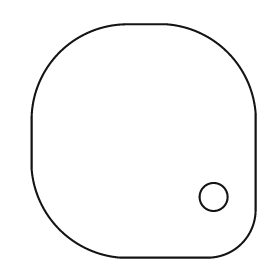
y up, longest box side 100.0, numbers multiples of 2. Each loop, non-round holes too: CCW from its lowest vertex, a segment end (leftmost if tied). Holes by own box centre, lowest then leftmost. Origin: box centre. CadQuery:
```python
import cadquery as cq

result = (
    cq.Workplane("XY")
    .moveTo(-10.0, -50.0)
    .lineTo(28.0, -50.0)
    .threePointArc((42.0, -44.0), (48.0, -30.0))
    .lineTo(48.0, 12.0)
    .threePointArc((36.0, 38.0), (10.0, 50.0))
    .lineTo(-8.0, 50.0)
    .threePointArc((-36.0, 38.0), (-48.0, 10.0))
    .lineTo(-48.0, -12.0)
    .threePointArc((-36.0, -38.0), (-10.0, -50.0))
    .close()
    .moveTo(30.0, -24.0)
    .circle(6.0)
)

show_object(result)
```